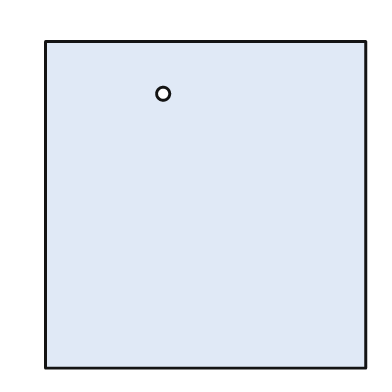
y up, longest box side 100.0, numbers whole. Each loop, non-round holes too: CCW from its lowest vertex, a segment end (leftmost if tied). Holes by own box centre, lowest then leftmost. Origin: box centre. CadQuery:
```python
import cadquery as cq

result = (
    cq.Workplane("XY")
    .moveTo(-49.0, -50.0)
    .lineTo(49.0, -50.0)
    .lineTo(49.0, 50.0)
    .lineTo(-49.0, 50.0)
    .close()
    .moveTo(-13.0, 34.0)
    .circle(2.0)
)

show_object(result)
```